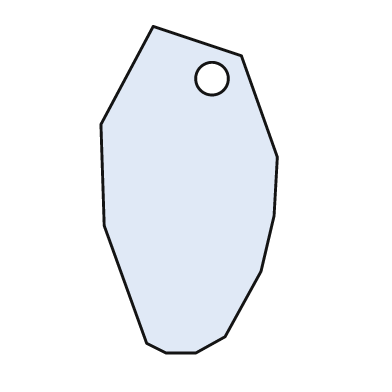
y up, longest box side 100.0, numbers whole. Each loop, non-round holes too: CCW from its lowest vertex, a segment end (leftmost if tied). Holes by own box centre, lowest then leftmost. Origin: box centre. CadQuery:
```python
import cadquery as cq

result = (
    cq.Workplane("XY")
    .moveTo(-7.0, -50.0)
    .lineTo(2.0, -50.0)
    .lineTo(11.0, -45.0)
    .lineTo(22.0, -25.0)
    .lineTo(26.0, -8.0)
    .lineTo(27.0, 10.0)
    .lineTo(16.0, 41.0)
    .lineTo(-11.0, 50.0)
    .lineTo(-27.0, 20.0)
    .lineTo(-26.0, -11.0)
    .lineTo(-13.0, -47.0)
    .close()
    .moveTo(7.0, 34.0)
    .circle(5.0)
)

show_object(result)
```